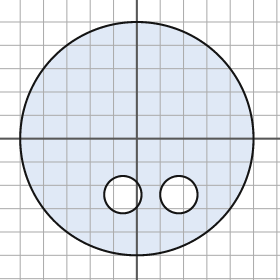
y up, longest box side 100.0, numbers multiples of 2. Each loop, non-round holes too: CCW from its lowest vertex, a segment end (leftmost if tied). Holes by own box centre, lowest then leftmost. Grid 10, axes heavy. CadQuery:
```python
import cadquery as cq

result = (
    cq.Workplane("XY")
    .moveTo(0.0, 0.0)
    .circle(50.0)
    .moveTo(-6.0, -24.0)
    .circle(8.0)
    .moveTo(18.0, -24.0)
    .circle(8.0)
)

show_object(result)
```